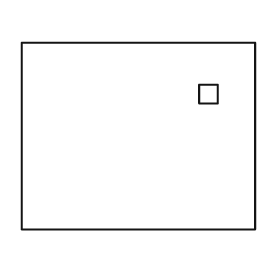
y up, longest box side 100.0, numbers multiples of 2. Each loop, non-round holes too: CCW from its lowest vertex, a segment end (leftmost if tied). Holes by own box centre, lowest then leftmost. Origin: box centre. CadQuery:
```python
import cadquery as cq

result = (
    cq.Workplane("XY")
    .moveTo(-50.0, -40.0)
    .lineTo(50.0, -40.0)
    .lineTo(50.0, 40.0)
    .lineTo(-50.0, 40.0)
    .close()
    .moveTo(26.0, 14.0)
    .lineTo(34.0, 14.0)
    .lineTo(34.0, 22.0)
    .lineTo(26.0, 22.0)
    .close()
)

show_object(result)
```